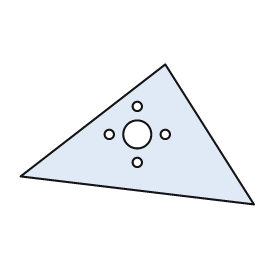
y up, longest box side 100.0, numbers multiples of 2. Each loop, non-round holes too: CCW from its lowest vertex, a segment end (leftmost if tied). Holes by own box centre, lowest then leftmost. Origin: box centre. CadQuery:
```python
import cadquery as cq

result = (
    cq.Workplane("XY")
    .moveTo(50.0, -30.0)
    .lineTo(12.0, 30.0)
    .lineTo(-50.0, -18.0)
    .close()
    .moveTo(0.0, -12.0)
    .circle(2.0)
    .moveTo(-12.0, 0.0)
    .circle(2.0)
    .moveTo(0.0, 0.0)
    .circle(6.0)
    .moveTo(12.0, 0.0)
    .circle(2.0)
    .moveTo(0.0, 12.0)
    .circle(2.0)
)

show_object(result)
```